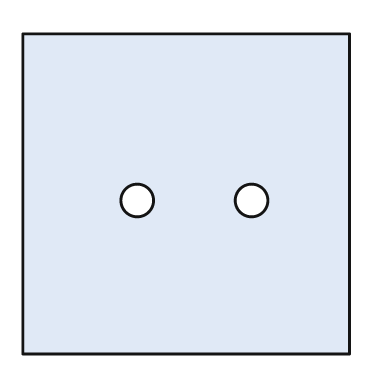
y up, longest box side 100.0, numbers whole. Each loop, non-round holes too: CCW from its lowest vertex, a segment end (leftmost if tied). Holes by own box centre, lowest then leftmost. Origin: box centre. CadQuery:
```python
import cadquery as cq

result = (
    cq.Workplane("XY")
    .moveTo(-50.0, -49.0)
    .lineTo(50.0, -49.0)
    .lineTo(50.0, 49.0)
    .lineTo(-50.0, 49.0)
    .close()
    .moveTo(-15.0, -2.0)
    .circle(5.0)
    .moveTo(20.0, -2.0)
    .circle(5.0)
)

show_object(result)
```